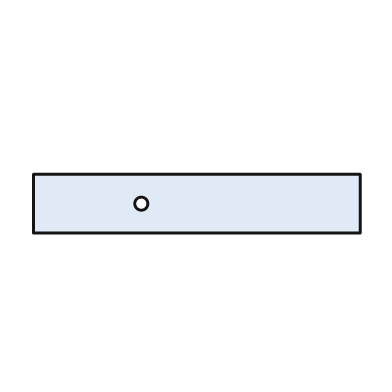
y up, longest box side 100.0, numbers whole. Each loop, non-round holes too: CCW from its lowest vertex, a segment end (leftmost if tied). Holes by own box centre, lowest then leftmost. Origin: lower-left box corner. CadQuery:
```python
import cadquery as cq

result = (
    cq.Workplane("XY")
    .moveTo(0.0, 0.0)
    .lineTo(100.0, 0.0)
    .lineTo(100.0, 18.0)
    .lineTo(0.0, 18.0)
    .close()
    .moveTo(33.0, 9.0)
    .circle(2.0)
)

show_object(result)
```